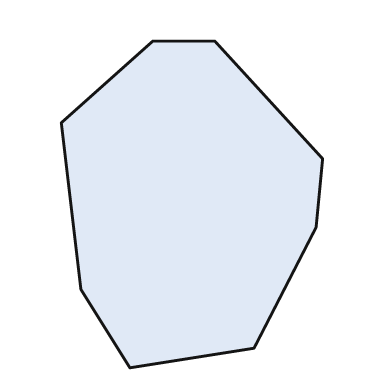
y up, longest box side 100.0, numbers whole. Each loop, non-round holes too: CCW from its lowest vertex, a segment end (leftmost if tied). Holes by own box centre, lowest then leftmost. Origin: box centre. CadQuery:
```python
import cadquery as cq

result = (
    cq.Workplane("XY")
    .moveTo(-19.0, -50.0)
    .lineTo(19.0, -44.0)
    .lineTo(38.0, -7.0)
    .lineTo(40.0, 14.0)
    .lineTo(7.0, 50.0)
    .lineTo(-12.0, 50.0)
    .lineTo(-40.0, 25.0)
    .lineTo(-34.0, -26.0)
    .close()
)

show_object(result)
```